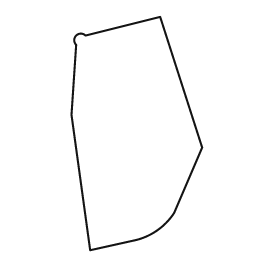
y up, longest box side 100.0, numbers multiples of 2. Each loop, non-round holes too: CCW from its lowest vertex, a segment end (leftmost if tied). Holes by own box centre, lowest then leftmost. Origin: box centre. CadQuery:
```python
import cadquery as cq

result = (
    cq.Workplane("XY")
    .moveTo(-20.0, -50.0)
    .lineTo(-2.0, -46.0)
    .threePointArc((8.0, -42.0), (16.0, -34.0))
    .lineTo(28.0, -6.0)
    .lineTo(10.0, 50.0)
    .lineTo(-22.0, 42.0)
    .threePointArc((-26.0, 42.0), (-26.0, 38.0))
    .lineTo(-28.0, 8.0)
    .close()
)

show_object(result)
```